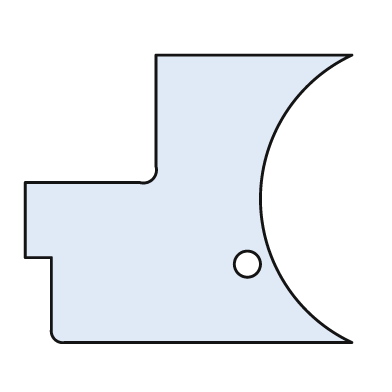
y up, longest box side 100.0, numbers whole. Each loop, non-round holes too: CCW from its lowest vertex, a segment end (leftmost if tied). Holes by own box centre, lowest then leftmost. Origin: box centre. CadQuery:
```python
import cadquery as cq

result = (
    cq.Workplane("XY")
    .moveTo(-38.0, -44.0)
    .lineTo(50.0, -44.0)
    .threePointArc((22.0, 0.0), (50.0, 44.0))
    .lineTo(-10.0, 44.0)
    .lineTo(-10.0, 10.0)
    .threePointArc((-11.0, 6.0), (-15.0, 5.0))
    .lineTo(-50.0, 5.0)
    .lineTo(-50.0, -18.0)
    .lineTo(-42.0, -18.0)
    .lineTo(-42.0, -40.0)
    .threePointArc((-41.0, -43.0), (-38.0, -44.0))
    .close()
    .moveTo(18.0, -20.0)
    .circle(4.0)
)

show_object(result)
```